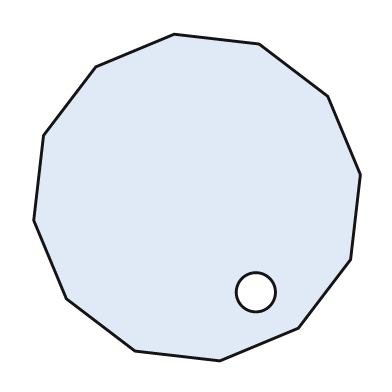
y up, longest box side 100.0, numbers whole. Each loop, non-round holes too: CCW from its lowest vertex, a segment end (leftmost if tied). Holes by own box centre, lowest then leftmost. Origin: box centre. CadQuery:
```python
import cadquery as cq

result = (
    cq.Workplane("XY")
    .moveTo(7.0, -50.0)
    .lineTo(31.0, -40.0)
    .lineTo(47.0, -19.0)
    .lineTo(50.0, 7.0)
    .lineTo(40.0, 31.0)
    .lineTo(19.0, 47.0)
    .lineTo(-7.0, 50.0)
    .lineTo(-31.0, 40.0)
    .lineTo(-47.0, 19.0)
    .lineTo(-50.0, -7.0)
    .lineTo(-40.0, -31.0)
    .lineTo(-19.0, -47.0)
    .close()
    .moveTo(18.0, -29.0)
    .circle(6.0)
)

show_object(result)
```